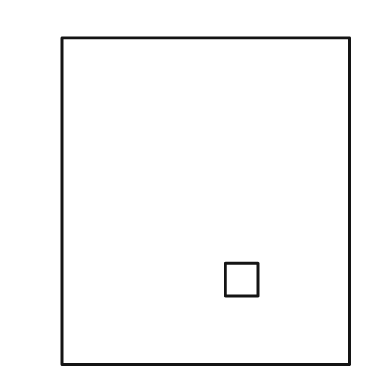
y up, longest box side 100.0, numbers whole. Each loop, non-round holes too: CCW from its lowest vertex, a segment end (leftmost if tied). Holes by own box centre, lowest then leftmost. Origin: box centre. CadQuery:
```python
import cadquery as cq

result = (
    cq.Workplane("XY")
    .moveTo(-44.0, -50.0)
    .lineTo(44.0, -50.0)
    .lineTo(44.0, 50.0)
    .lineTo(-44.0, 50.0)
    .close()
    .moveTo(6.0, -29.0)
    .lineTo(16.0, -29.0)
    .lineTo(16.0, -19.0)
    .lineTo(6.0, -19.0)
    .close()
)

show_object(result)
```